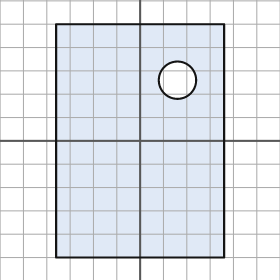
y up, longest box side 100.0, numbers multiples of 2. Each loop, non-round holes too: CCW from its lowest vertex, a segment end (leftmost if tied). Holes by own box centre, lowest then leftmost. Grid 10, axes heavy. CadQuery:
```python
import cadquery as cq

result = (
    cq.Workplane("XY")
    .moveTo(-36.0, -50.0)
    .lineTo(36.0, -50.0)
    .lineTo(36.0, 50.0)
    .lineTo(-36.0, 50.0)
    .close()
    .moveTo(16.0, 26.0)
    .circle(8.0)
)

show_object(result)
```